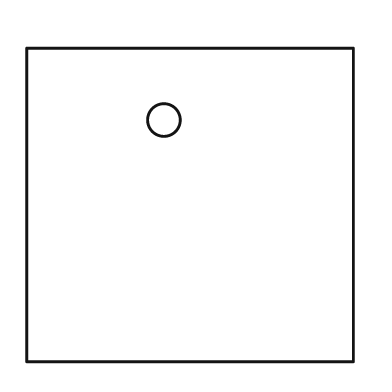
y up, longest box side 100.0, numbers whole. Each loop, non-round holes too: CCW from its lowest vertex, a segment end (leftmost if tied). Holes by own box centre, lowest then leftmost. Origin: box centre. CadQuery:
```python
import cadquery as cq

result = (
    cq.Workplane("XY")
    .moveTo(-50.0, -48.0)
    .lineTo(50.0, -48.0)
    .lineTo(50.0, 48.0)
    .lineTo(-50.0, 48.0)
    .close()
    .moveTo(-8.0, 26.0)
    .circle(5.0)
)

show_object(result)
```